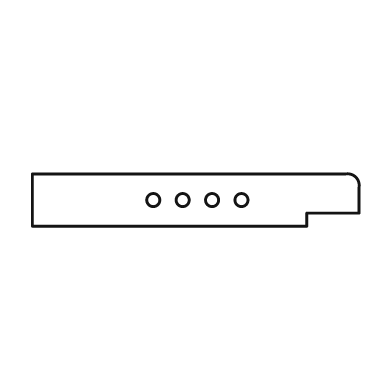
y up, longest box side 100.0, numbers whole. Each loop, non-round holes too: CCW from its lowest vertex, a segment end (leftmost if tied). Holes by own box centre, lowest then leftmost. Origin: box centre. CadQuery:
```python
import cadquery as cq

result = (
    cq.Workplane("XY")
    .moveTo(-50.0, -8.0)
    .lineTo(34.0, -8.0)
    .lineTo(34.0, -4.0)
    .lineTo(50.0, -4.0)
    .lineTo(50.0, 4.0)
    .threePointArc((49.0, 7.0), (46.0, 8.0))
    .lineTo(-50.0, 8.0)
    .close()
    .moveTo(-13.0, 0.0)
    .circle(2.0)
    .moveTo(-4.0, 0.0)
    .circle(2.0)
    .moveTo(5.0, 0.0)
    .circle(2.0)
    .moveTo(14.0, 0.0)
    .circle(2.0)
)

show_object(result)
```